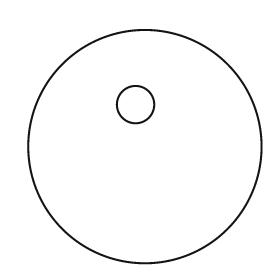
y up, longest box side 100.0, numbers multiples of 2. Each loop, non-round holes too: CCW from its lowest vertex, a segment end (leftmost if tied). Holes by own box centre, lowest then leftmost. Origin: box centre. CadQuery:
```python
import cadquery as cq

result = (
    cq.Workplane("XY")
    .moveTo(0.0, 0.0)
    .circle(50.0)
    .moveTo(-4.0, 18.0)
    .circle(8.0)
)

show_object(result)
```